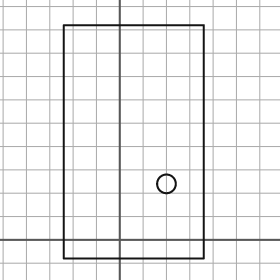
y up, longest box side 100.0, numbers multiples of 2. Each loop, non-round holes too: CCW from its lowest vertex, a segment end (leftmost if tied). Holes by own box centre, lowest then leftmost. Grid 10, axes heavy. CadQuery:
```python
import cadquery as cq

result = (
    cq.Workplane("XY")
    .moveTo(-24.0, -8.0)
    .lineTo(36.0, -8.0)
    .lineTo(36.0, 92.0)
    .lineTo(-24.0, 92.0)
    .close()
    .moveTo(20.0, 24.0)
    .circle(4.0)
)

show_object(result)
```